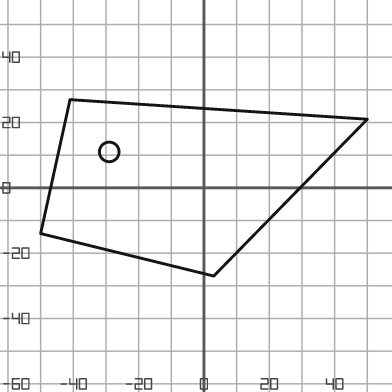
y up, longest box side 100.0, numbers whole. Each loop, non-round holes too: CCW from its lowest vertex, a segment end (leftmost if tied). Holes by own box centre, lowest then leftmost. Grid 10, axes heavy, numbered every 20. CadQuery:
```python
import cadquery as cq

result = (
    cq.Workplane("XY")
    .moveTo(3.0, -27.0)
    .lineTo(50.0, 21.0)
    .lineTo(-41.0, 27.0)
    .lineTo(-50.0, -14.0)
    .close()
    .moveTo(-29.0, 11.0)
    .circle(3.0)
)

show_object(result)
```